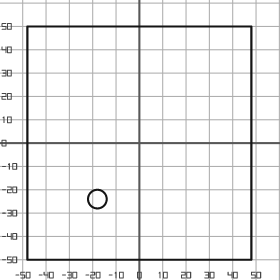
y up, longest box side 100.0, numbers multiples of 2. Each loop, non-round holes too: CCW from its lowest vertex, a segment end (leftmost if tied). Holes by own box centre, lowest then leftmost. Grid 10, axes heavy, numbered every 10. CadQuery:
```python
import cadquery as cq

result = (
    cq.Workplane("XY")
    .moveTo(-48.0, -50.0)
    .lineTo(48.0, -50.0)
    .lineTo(48.0, 50.0)
    .lineTo(-48.0, 50.0)
    .close()
    .moveTo(-18.0, -24.0)
    .circle(4.0)
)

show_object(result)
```